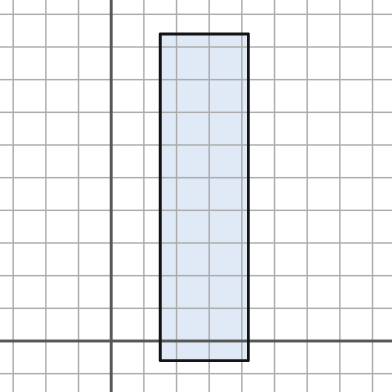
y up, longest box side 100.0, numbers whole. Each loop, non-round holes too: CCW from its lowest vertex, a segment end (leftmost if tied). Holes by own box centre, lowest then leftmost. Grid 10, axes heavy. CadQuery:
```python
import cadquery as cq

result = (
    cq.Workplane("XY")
    .moveTo(15.0, -6.0)
    .lineTo(42.0, -6.0)
    .lineTo(42.0, 94.0)
    .lineTo(15.0, 94.0)
    .close()
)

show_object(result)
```